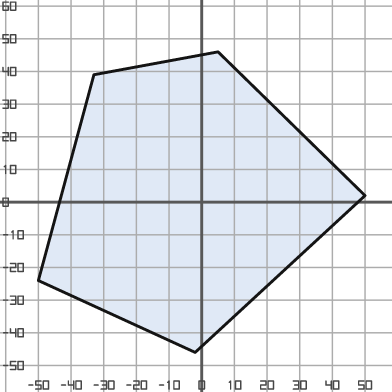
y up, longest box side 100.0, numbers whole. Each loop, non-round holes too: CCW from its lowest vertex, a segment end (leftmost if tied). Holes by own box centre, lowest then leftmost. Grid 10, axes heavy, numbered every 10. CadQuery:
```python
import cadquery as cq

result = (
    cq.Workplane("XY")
    .moveTo(-2.0, -46.0)
    .lineTo(50.0, 2.0)
    .lineTo(5.0, 46.0)
    .lineTo(-33.0, 39.0)
    .lineTo(-50.0, -24.0)
    .close()
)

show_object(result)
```